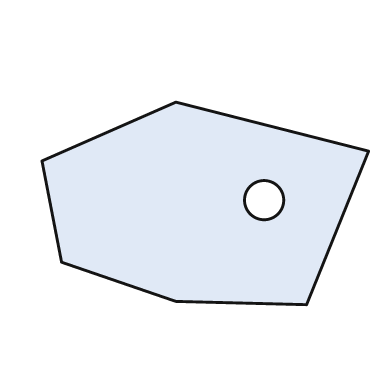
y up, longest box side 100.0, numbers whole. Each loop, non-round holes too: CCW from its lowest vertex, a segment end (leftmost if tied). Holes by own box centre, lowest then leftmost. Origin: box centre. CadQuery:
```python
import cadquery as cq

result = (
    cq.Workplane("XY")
    .moveTo(31.0, -31.0)
    .lineTo(50.0, 16.0)
    .lineTo(-9.0, 31.0)
    .lineTo(-50.0, 13.0)
    .lineTo(-44.0, -18.0)
    .lineTo(-9.0, -30.0)
    .close()
    .moveTo(18.0, 1.0)
    .circle(6.0)
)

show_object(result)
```